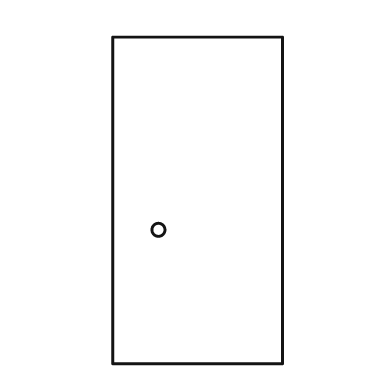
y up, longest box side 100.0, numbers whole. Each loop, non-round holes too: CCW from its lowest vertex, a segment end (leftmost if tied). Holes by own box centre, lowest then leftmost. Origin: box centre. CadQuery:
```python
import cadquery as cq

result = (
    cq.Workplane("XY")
    .moveTo(-26.0, -50.0)
    .lineTo(26.0, -50.0)
    .lineTo(26.0, 50.0)
    .lineTo(-26.0, 50.0)
    .close()
    .moveTo(-12.0, -9.0)
    .circle(2.0)
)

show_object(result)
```